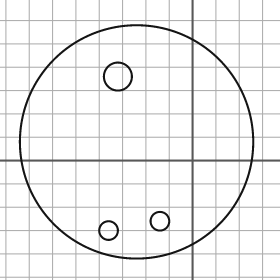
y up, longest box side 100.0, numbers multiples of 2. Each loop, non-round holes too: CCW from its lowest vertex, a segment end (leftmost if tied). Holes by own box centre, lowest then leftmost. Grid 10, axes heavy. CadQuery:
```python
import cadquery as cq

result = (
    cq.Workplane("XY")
    .moveTo(-24.0, 8.0)
    .circle(50.0)
    .moveTo(-36.0, -30.0)
    .circle(4.0)
    .moveTo(-14.0, -26.0)
    .circle(4.0)
    .moveTo(-32.0, 36.0)
    .circle(6.0)
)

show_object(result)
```